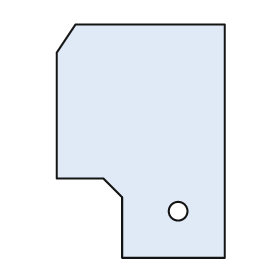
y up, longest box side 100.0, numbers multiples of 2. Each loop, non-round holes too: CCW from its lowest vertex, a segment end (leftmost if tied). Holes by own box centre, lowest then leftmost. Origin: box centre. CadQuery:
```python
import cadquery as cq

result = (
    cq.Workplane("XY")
    .moveTo(-8.0, -50.0)
    .lineTo(36.0, -50.0)
    .lineTo(36.0, 50.0)
    .lineTo(-28.0, 50.0)
    .lineTo(-36.0, 38.0)
    .lineTo(-36.0, -16.0)
    .lineTo(-16.0, -16.0)
    .lineTo(-8.0, -24.0)
    .close()
    .moveTo(16.0, -30.0)
    .circle(4.0)
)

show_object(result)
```